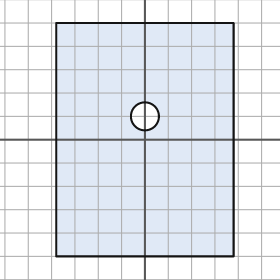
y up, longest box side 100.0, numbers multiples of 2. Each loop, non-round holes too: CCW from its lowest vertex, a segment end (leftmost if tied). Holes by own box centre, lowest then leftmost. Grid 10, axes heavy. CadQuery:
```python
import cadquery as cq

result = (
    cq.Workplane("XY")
    .moveTo(-38.0, -50.0)
    .lineTo(38.0, -50.0)
    .lineTo(38.0, 50.0)
    .lineTo(-38.0, 50.0)
    .close()
    .moveTo(0.0, 10.0)
    .circle(6.0)
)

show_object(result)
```